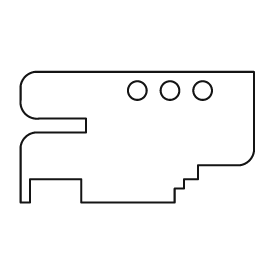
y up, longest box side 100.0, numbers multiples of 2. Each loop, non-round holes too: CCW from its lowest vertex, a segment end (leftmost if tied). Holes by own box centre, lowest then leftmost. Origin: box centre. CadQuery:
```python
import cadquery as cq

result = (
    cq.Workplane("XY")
    .moveTo(-50.0, -28.0)
    .lineTo(-46.0, -28.0)
    .lineTo(-46.0, -18.0)
    .lineTo(-24.0, -18.0)
    .lineTo(-24.0, -28.0)
    .lineTo(16.0, -28.0)
    .lineTo(16.0, -22.0)
    .lineTo(20.0, -22.0)
    .lineTo(20.0, -18.0)
    .lineTo(26.0, -18.0)
    .lineTo(26.0, -12.0)
    .lineTo(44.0, -12.0)
    .threePointArc((48.0, -10.0), (50.0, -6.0))
    .lineTo(50.0, 28.0)
    .lineTo(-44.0, 28.0)
    .threePointArc((-48.0, 26.0), (-50.0, 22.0))
    .lineTo(-50.0, 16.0)
    .threePointArc((-48.0, 10.0), (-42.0, 8.0))
    .lineTo(-22.0, 8.0)
    .lineTo(-22.0, 2.0)
    .lineTo(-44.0, 2.0)
    .threePointArc((-48.0, 0.0), (-50.0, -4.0))
    .close()
    .moveTo(0.0, 20.0)
    .circle(4.0)
    .moveTo(14.0, 20.0)
    .circle(4.0)
    .moveTo(28.0, 20.0)
    .circle(4.0)
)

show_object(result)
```